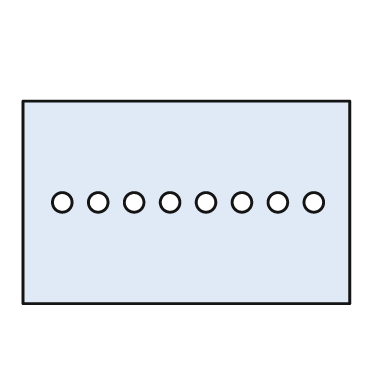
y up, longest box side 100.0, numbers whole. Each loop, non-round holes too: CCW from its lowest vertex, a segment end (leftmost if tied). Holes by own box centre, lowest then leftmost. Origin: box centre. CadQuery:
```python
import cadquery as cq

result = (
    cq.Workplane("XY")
    .moveTo(-50.0, -31.0)
    .lineTo(50.0, -31.0)
    .lineTo(50.0, 31.0)
    .lineTo(-50.0, 31.0)
    .close()
    .moveTo(-38.0, 0.0)
    .circle(3.0)
    .moveTo(-27.0, 0.0)
    .circle(3.0)
    .moveTo(-16.0, 0.0)
    .circle(3.0)
    .moveTo(-5.0, 0.0)
    .circle(3.0)
    .moveTo(6.0, 0.0)
    .circle(3.0)
    .moveTo(17.0, 0.0)
    .circle(3.0)
    .moveTo(28.0, 0.0)
    .circle(3.0)
    .moveTo(39.0, 0.0)
    .circle(3.0)
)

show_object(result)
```